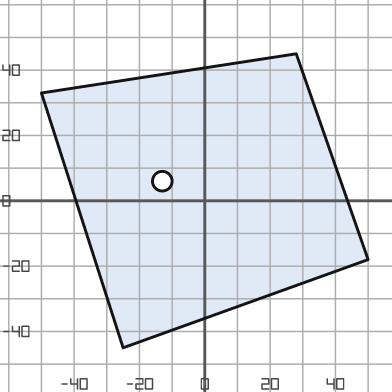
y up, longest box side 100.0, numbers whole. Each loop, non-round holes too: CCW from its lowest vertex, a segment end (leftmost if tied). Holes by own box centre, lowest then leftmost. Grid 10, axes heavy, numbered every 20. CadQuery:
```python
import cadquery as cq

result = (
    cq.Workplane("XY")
    .moveTo(-25.0, -45.0)
    .lineTo(50.0, -18.0)
    .lineTo(28.0, 45.0)
    .lineTo(-50.0, 33.0)
    .close()
    .moveTo(-13.0, 6.0)
    .circle(3.0)
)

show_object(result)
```